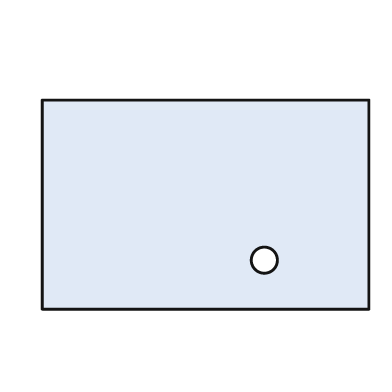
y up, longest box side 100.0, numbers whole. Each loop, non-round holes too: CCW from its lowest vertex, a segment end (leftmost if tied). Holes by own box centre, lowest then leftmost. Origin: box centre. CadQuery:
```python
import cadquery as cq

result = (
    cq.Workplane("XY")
    .moveTo(-50.0, -32.0)
    .lineTo(50.0, -32.0)
    .lineTo(50.0, 32.0)
    .lineTo(-50.0, 32.0)
    .close()
    .moveTo(18.0, -17.0)
    .circle(4.0)
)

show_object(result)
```